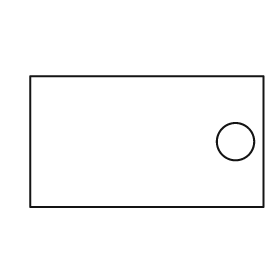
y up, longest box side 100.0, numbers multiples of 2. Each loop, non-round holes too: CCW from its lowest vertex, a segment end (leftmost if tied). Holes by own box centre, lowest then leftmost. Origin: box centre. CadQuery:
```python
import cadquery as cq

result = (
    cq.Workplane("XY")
    .moveTo(-50.0, -28.0)
    .lineTo(50.0, -28.0)
    .lineTo(50.0, 28.0)
    .lineTo(-50.0, 28.0)
    .close()
    .moveTo(38.0, 0.0)
    .circle(8.0)
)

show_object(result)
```